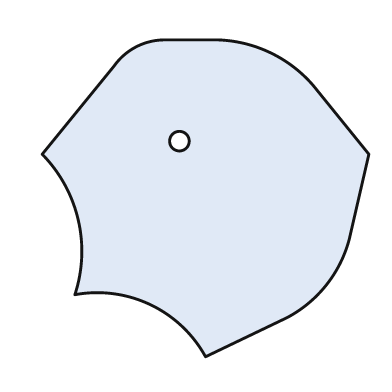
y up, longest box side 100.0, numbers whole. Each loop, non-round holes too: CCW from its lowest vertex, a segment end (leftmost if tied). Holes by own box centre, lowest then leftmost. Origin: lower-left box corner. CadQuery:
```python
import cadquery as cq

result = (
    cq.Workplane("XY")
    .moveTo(50.0, 0.0)
    .lineTo(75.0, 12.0)
    .threePointArc((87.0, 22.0), (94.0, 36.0))
    .lineTo(100.0, 62.0)
    .lineTo(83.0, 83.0)
    .threePointArc((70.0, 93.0), (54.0, 97.0))
    .lineTo(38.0, 97.0)
    .threePointArc((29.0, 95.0), (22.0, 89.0))
    .lineTo(0.0, 62.0)
    .threePointArc((11.0, 42.0), (10.0, 19.0))
    .threePointArc((33.0, 16.0), (50.0, 0.0))
    .close()
    .moveTo(42.0, 66.0)
    .circle(3.0)
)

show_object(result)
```